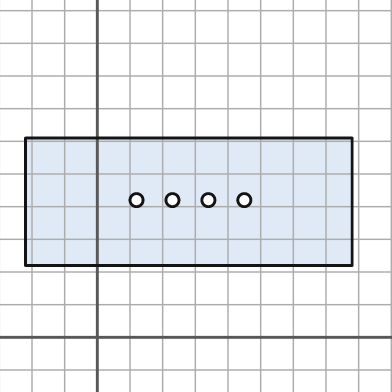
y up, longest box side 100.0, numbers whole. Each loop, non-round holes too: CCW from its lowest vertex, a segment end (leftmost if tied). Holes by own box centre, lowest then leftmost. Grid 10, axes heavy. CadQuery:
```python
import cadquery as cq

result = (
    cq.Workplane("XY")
    .moveTo(-22.0, 22.0)
    .lineTo(78.0, 22.0)
    .lineTo(78.0, 61.0)
    .lineTo(-22.0, 61.0)
    .close()
    .moveTo(12.0, 42.0)
    .circle(2.0)
    .moveTo(23.0, 42.0)
    .circle(2.0)
    .moveTo(34.0, 42.0)
    .circle(2.0)
    .moveTo(45.0, 42.0)
    .circle(2.0)
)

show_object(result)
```